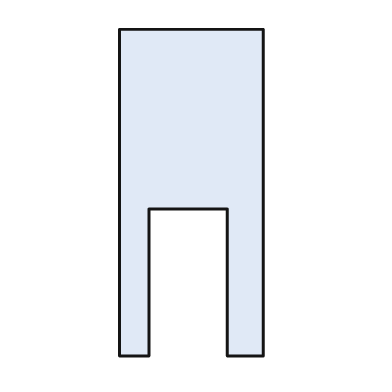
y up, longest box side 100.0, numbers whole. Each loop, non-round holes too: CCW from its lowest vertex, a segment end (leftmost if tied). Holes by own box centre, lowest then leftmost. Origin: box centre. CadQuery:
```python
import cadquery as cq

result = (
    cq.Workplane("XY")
    .moveTo(-22.0, -50.0)
    .lineTo(-13.0, -50.0)
    .lineTo(-13.0, -5.0)
    .lineTo(11.0, -5.0)
    .lineTo(11.0, -50.0)
    .lineTo(22.0, -50.0)
    .lineTo(22.0, 50.0)
    .lineTo(-22.0, 50.0)
    .close()
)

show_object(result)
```